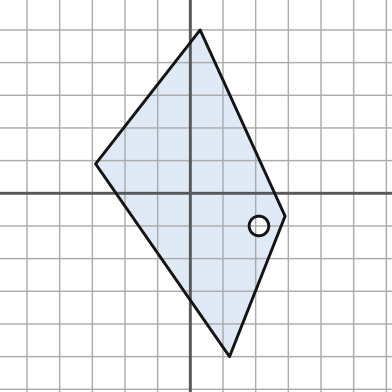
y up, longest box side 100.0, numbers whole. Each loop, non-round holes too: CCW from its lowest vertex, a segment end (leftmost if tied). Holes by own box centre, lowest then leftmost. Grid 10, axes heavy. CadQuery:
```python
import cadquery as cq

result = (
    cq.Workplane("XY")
    .moveTo(12.0, -50.0)
    .lineTo(29.0, -7.0)
    .lineTo(3.0, 50.0)
    .lineTo(-29.0, 9.0)
    .close()
    .moveTo(21.0, -10.0)
    .circle(3.0)
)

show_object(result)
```